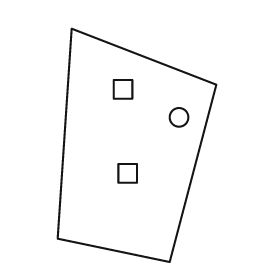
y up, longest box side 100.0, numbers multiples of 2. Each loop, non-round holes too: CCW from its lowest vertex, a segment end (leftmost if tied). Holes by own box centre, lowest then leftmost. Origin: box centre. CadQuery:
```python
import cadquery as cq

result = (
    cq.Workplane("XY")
    .moveTo(14.0, -50.0)
    .lineTo(34.0, 26.0)
    .lineTo(-28.0, 50.0)
    .lineTo(-34.0, -40.0)
    .close()
    .moveTo(-8.0, -16.0)
    .lineTo(0.0, -16.0)
    .lineTo(0.0, -8.0)
    .lineTo(-8.0, -8.0)
    .close()
    .moveTo(18.0, 12.0)
    .circle(4.0)
    .moveTo(-10.0, 20.0)
    .lineTo(-2.0, 20.0)
    .lineTo(-2.0, 28.0)
    .lineTo(-10.0, 28.0)
    .close()
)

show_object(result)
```